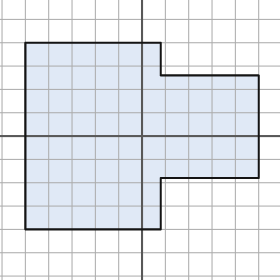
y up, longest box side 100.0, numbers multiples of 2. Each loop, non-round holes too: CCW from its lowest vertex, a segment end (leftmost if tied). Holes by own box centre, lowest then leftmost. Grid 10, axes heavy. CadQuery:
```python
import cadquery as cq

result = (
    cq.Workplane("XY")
    .moveTo(-50.0, -40.0)
    .lineTo(8.0, -40.0)
    .lineTo(8.0, -18.0)
    .lineTo(50.0, -18.0)
    .lineTo(50.0, 26.0)
    .lineTo(8.0, 26.0)
    .lineTo(8.0, 40.0)
    .lineTo(-50.0, 40.0)
    .close()
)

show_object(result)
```